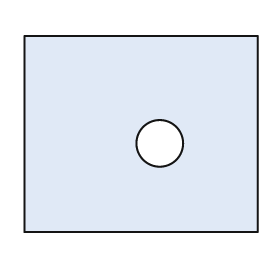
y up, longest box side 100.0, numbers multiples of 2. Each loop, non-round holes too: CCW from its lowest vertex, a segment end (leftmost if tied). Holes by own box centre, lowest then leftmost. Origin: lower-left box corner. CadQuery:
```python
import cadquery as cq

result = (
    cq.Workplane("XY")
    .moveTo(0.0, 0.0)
    .lineTo(100.0, 0.0)
    .lineTo(100.0, 84.0)
    .lineTo(0.0, 84.0)
    .close()
    .moveTo(58.0, 38.0)
    .circle(10.0)
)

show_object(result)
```